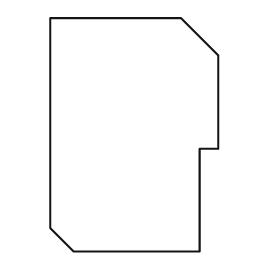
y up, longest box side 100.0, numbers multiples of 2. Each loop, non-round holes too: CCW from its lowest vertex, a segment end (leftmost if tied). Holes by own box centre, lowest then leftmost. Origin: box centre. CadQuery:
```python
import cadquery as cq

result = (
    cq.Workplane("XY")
    .moveTo(-26.0, -50.0)
    .lineTo(28.0, -50.0)
    .lineTo(28.0, -6.0)
    .lineTo(36.0, -6.0)
    .lineTo(36.0, 34.0)
    .lineTo(20.0, 50.0)
    .lineTo(-36.0, 50.0)
    .lineTo(-36.0, -40.0)
    .close()
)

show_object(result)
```